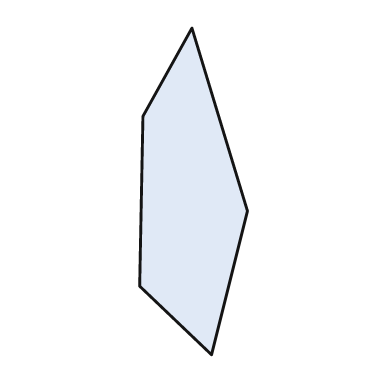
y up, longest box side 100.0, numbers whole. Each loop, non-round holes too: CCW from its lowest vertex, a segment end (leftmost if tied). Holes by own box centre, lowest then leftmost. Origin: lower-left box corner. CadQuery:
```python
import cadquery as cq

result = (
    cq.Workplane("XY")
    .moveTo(22.0, 0.0)
    .lineTo(33.0, 44.0)
    .lineTo(16.0, 100.0)
    .lineTo(1.0, 73.0)
    .lineTo(0.0, 21.0)
    .close()
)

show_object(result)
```